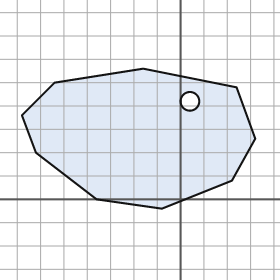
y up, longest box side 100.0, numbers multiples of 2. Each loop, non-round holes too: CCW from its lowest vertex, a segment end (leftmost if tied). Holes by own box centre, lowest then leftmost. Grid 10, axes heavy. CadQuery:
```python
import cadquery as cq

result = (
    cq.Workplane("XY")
    .moveTo(-8.0, -4.0)
    .lineTo(22.0, 8.0)
    .lineTo(32.0, 26.0)
    .lineTo(24.0, 48.0)
    .lineTo(-16.0, 56.0)
    .lineTo(-54.0, 50.0)
    .lineTo(-68.0, 36.0)
    .lineTo(-62.0, 20.0)
    .lineTo(-36.0, 0.0)
    .close()
    .moveTo(4.0, 42.0)
    .circle(4.0)
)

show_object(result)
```